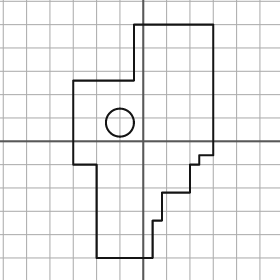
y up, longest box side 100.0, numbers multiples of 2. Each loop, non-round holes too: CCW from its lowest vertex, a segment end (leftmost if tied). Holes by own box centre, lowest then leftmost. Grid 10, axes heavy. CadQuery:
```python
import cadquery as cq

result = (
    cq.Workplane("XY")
    .moveTo(-20.0, -50.0)
    .lineTo(4.0, -50.0)
    .lineTo(4.0, -34.0)
    .lineTo(8.0, -34.0)
    .lineTo(8.0, -22.0)
    .lineTo(20.0, -22.0)
    .lineTo(20.0, -10.0)
    .lineTo(24.0, -10.0)
    .lineTo(24.0, -6.0)
    .lineTo(30.0, -6.0)
    .lineTo(30.0, 50.0)
    .lineTo(-4.0, 50.0)
    .lineTo(-4.0, 26.0)
    .lineTo(-30.0, 26.0)
    .lineTo(-30.0, -10.0)
    .lineTo(-20.0, -10.0)
    .close()
    .moveTo(-10.0, 8.0)
    .circle(6.0)
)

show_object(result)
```